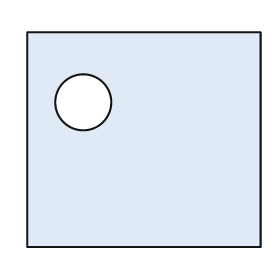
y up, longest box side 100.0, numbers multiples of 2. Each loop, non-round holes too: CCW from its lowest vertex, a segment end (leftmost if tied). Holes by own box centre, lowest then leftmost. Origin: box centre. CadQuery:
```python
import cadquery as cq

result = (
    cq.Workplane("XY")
    .moveTo(-50.0, -46.0)
    .lineTo(50.0, -46.0)
    .lineTo(50.0, 46.0)
    .lineTo(-50.0, 46.0)
    .close()
    .moveTo(-26.0, 16.0)
    .circle(12.0)
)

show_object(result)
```